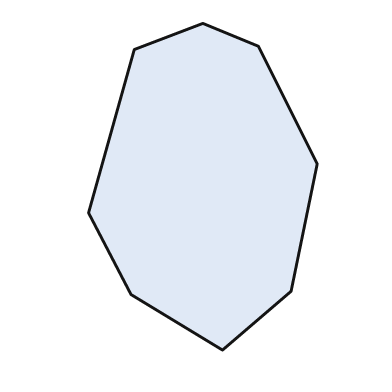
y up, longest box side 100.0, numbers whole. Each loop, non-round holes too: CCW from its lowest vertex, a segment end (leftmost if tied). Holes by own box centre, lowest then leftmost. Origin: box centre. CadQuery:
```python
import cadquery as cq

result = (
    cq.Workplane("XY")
    .moveTo(6.0, -50.0)
    .lineTo(27.0, -32.0)
    .lineTo(35.0, 7.0)
    .lineTo(17.0, 43.0)
    .lineTo(0.0, 50.0)
    .lineTo(-21.0, 42.0)
    .lineTo(-35.0, -8.0)
    .lineTo(-22.0, -33.0)
    .close()
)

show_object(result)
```